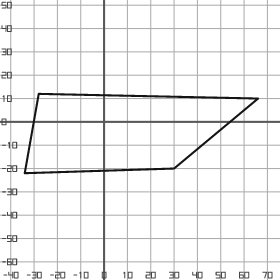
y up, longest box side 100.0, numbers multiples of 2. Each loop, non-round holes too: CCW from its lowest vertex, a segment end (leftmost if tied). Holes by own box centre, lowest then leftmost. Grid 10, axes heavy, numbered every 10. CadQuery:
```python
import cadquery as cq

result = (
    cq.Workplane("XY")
    .moveTo(-34.0, -22.0)
    .lineTo(30.0, -20.0)
    .lineTo(66.0, 10.0)
    .lineTo(-28.0, 12.0)
    .close()
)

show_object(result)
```